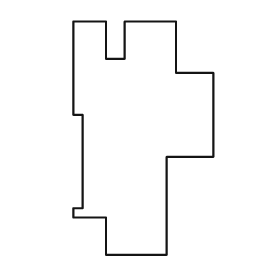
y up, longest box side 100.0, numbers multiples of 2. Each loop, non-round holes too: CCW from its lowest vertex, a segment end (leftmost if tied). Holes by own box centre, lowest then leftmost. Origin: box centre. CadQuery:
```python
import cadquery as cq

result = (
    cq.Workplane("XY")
    .moveTo(-16.0, -50.0)
    .lineTo(10.0, -50.0)
    .lineTo(10.0, -8.0)
    .lineTo(30.0, -8.0)
    .lineTo(30.0, 28.0)
    .lineTo(14.0, 28.0)
    .lineTo(14.0, 50.0)
    .lineTo(-8.0, 50.0)
    .lineTo(-8.0, 34.0)
    .lineTo(-16.0, 34.0)
    .lineTo(-16.0, 50.0)
    .lineTo(-30.0, 50.0)
    .lineTo(-30.0, 10.0)
    .lineTo(-26.0, 10.0)
    .lineTo(-26.0, -30.0)
    .lineTo(-30.0, -30.0)
    .lineTo(-30.0, -34.0)
    .lineTo(-16.0, -34.0)
    .close()
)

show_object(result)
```